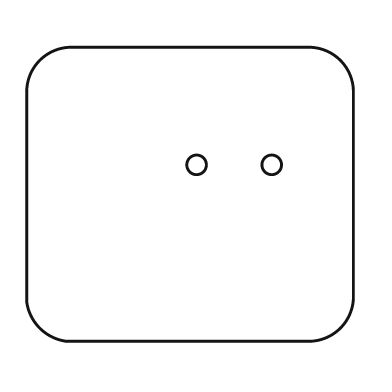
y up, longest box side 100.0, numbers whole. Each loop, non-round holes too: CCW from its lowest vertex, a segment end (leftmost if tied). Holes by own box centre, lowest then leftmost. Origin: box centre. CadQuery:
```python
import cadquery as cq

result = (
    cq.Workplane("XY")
    .moveTo(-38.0, -45.0)
    .lineTo(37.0, -45.0)
    .threePointArc((46.0, -41.0), (50.0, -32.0))
    .lineTo(50.0, 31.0)
    .threePointArc((46.0, 41.0), (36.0, 45.0))
    .lineTo(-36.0, 45.0)
    .threePointArc((-46.0, 41.0), (-50.0, 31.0))
    .lineTo(-50.0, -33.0)
    .threePointArc((-46.0, -41.0), (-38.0, -45.0))
    .close()
    .moveTo(2.0, 9.0)
    .circle(3.0)
    .moveTo(25.0, 9.0)
    .circle(3.0)
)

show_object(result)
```